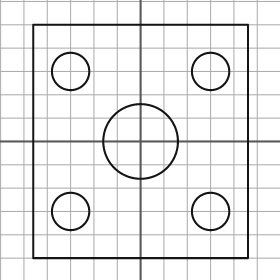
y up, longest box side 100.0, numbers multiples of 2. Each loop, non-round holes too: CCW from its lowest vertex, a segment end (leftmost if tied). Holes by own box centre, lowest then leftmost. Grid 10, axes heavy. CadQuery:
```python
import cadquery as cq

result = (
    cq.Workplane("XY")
    .moveTo(-46.0, -50.0)
    .lineTo(46.0, -50.0)
    .lineTo(46.0, 50.0)
    .lineTo(-46.0, 50.0)
    .close()
    .moveTo(-30.0, -30.0)
    .circle(8.0)
    .moveTo(30.0, -30.0)
    .circle(8.0)
    .moveTo(0.0, 0.0)
    .circle(16.0)
    .moveTo(-30.0, 30.0)
    .circle(8.0)
    .moveTo(30.0, 30.0)
    .circle(8.0)
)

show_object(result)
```